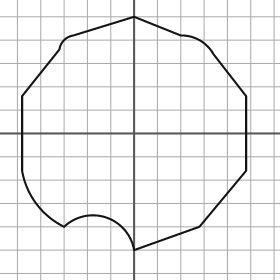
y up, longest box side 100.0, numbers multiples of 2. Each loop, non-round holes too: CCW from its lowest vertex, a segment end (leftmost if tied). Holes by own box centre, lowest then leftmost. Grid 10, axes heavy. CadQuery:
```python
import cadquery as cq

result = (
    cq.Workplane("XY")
    .moveTo(0.0, -50.0)
    .lineTo(28.0, -40.0)
    .lineTo(48.0, -16.0)
    .lineTo(48.0, 16.0)
    .lineTo(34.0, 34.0)
    .threePointArc((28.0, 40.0), (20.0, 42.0))
    .lineTo(0.0, 50.0)
    .lineTo(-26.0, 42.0)
    .threePointArc((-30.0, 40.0), (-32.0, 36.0))
    .lineTo(-48.0, 16.0)
    .lineTo(-48.0, -16.0)
    .threePointArc((-42.0, -30.0), (-30.0, -40.0))
    .threePointArc((-12.0, -36.0), (0.0, -50.0))
    .close()
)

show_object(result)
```